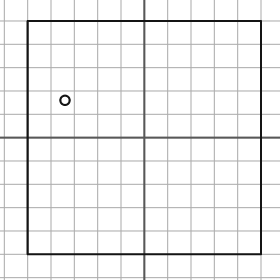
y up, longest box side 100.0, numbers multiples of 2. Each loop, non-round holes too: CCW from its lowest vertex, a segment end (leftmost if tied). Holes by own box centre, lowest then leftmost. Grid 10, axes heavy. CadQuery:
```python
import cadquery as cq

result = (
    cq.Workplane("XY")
    .moveTo(-50.0, -50.0)
    .lineTo(50.0, -50.0)
    .lineTo(50.0, 50.0)
    .lineTo(-50.0, 50.0)
    .close()
    .moveTo(-34.0, 16.0)
    .circle(2.0)
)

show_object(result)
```